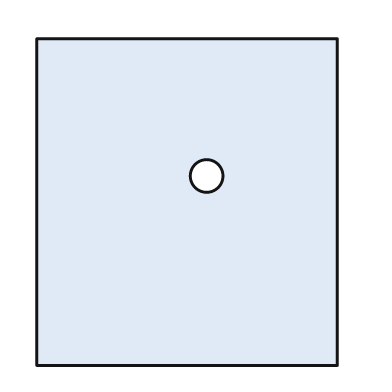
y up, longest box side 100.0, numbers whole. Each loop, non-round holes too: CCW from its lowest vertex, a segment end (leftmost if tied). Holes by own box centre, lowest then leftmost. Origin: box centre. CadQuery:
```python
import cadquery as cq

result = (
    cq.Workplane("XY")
    .moveTo(-46.0, -50.0)
    .lineTo(46.0, -50.0)
    .lineTo(46.0, 50.0)
    .lineTo(-46.0, 50.0)
    .close()
    .moveTo(6.0, 8.0)
    .circle(5.0)
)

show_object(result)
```